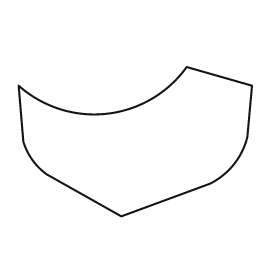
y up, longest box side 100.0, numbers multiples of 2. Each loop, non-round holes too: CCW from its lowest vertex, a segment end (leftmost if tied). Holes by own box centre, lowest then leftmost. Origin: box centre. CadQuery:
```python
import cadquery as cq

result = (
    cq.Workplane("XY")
    .moveTo(-6.0, -32.0)
    .lineTo(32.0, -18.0)
    .threePointArc((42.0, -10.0), (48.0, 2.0))
    .lineTo(50.0, 24.0)
    .lineTo(22.0, 32.0)
    .threePointArc((-12.0, 12.0), (-50.0, 24.0))
    .lineTo(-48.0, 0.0)
    .threePointArc((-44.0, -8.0), (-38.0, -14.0))
    .close()
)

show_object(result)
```